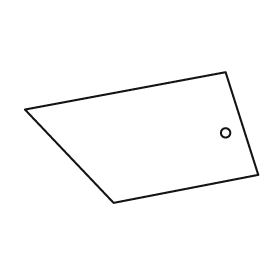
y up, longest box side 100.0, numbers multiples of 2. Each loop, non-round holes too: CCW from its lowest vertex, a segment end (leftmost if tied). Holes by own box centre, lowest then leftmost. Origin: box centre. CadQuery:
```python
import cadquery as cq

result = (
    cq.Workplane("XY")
    .moveTo(-12.0, -28.0)
    .lineTo(50.0, -16.0)
    .lineTo(36.0, 28.0)
    .lineTo(-50.0, 12.0)
    .close()
    .moveTo(36.0, 2.0)
    .circle(2.0)
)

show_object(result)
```